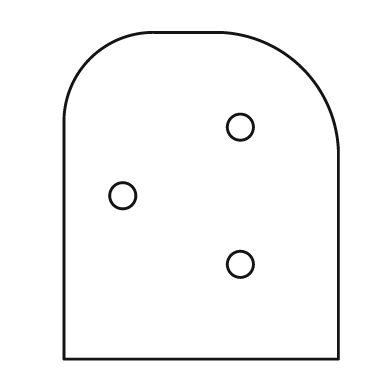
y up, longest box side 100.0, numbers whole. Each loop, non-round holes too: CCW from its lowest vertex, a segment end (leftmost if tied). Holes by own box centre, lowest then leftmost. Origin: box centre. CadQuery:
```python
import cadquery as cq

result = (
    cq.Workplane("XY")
    .moveTo(-42.0, -50.0)
    .lineTo(42.0, -50.0)
    .lineTo(42.0, 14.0)
    .threePointArc((31.0, 39.0), (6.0, 50.0))
    .lineTo(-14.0, 50.0)
    .threePointArc((-34.0, 42.0), (-42.0, 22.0))
    .close()
    .moveTo(12.0, -21.0)
    .circle(4.0)
    .moveTo(-24.0, 0.0)
    .circle(4.0)
    .moveTo(12.0, 21.0)
    .circle(4.0)
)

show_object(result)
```